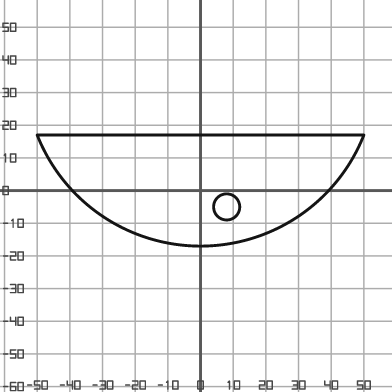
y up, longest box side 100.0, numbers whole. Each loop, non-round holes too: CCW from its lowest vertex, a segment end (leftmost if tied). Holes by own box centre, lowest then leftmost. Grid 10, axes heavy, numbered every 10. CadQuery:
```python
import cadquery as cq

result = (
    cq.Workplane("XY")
    .moveTo(-50.0, 17.0)
    .threePointArc((0.0, -17.0), (50.0, 17.0))
    .close()
    .moveTo(8.0, -5.0)
    .circle(4.0)
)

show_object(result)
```